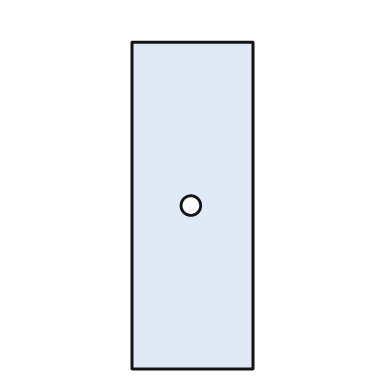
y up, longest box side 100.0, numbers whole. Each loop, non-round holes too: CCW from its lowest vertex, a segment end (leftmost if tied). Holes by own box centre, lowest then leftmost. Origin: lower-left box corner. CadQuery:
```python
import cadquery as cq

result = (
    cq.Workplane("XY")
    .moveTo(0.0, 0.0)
    .lineTo(37.0, 0.0)
    .lineTo(37.0, 100.0)
    .lineTo(0.0, 100.0)
    .close()
    .moveTo(18.0, 50.0)
    .circle(3.0)
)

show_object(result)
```